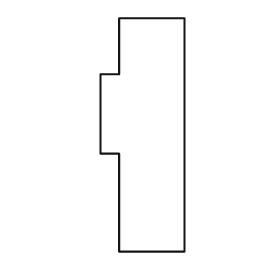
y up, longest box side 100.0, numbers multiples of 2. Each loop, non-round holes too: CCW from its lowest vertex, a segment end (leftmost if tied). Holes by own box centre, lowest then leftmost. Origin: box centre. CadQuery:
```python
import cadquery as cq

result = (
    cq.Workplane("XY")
    .moveTo(-10.0, -50.0)
    .lineTo(18.0, -50.0)
    .lineTo(18.0, 50.0)
    .lineTo(-10.0, 50.0)
    .lineTo(-10.0, 26.0)
    .lineTo(-18.0, 26.0)
    .lineTo(-18.0, -8.0)
    .lineTo(-10.0, -8.0)
    .close()
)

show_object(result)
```